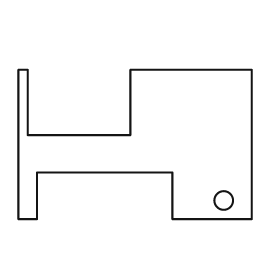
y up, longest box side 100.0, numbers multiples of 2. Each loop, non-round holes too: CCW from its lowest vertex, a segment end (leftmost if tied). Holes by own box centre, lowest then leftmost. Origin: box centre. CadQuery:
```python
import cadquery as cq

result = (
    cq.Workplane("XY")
    .moveTo(-50.0, -32.0)
    .lineTo(-42.0, -32.0)
    .lineTo(-42.0, -12.0)
    .lineTo(16.0, -12.0)
    .lineTo(16.0, -32.0)
    .lineTo(50.0, -32.0)
    .lineTo(50.0, 32.0)
    .lineTo(-2.0, 32.0)
    .lineTo(-2.0, 4.0)
    .lineTo(-46.0, 4.0)
    .lineTo(-46.0, 32.0)
    .lineTo(-50.0, 32.0)
    .close()
    .moveTo(38.0, -24.0)
    .circle(4.0)
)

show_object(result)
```